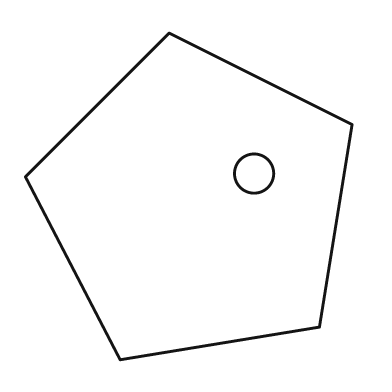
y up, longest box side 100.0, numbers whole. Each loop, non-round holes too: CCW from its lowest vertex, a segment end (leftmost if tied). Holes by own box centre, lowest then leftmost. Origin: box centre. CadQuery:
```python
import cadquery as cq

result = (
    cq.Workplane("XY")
    .moveTo(-21.0, -50.0)
    .lineTo(40.0, -40.0)
    .lineTo(50.0, 22.0)
    .lineTo(-6.0, 50.0)
    .lineTo(-50.0, 6.0)
    .close()
    .moveTo(20.0, 7.0)
    .circle(6.0)
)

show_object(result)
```